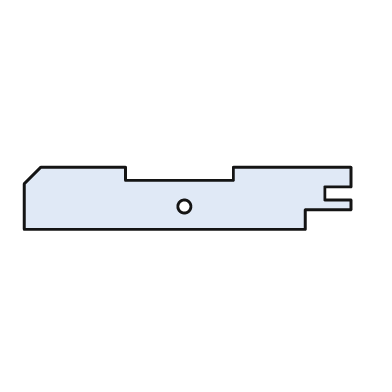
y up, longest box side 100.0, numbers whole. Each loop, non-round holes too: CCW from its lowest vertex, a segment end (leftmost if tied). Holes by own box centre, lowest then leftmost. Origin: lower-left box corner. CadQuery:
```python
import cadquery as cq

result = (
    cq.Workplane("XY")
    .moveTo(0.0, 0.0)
    .lineTo(86.0, 0.0)
    .lineTo(86.0, 6.0)
    .lineTo(100.0, 6.0)
    .lineTo(100.0, 9.0)
    .lineTo(92.0, 9.0)
    .lineTo(92.0, 13.0)
    .lineTo(100.0, 13.0)
    .lineTo(100.0, 19.0)
    .lineTo(64.0, 19.0)
    .lineTo(64.0, 15.0)
    .lineTo(31.0, 15.0)
    .lineTo(31.0, 19.0)
    .lineTo(5.0, 19.0)
    .lineTo(0.0, 14.0)
    .close()
    .moveTo(49.0, 7.0)
    .circle(2.0)
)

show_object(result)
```